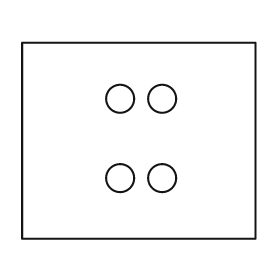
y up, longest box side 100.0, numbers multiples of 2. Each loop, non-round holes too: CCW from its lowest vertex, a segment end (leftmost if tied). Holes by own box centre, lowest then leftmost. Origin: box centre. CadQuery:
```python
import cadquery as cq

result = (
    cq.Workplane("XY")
    .moveTo(-50.0, -42.0)
    .lineTo(50.0, -42.0)
    .lineTo(50.0, 42.0)
    .lineTo(-50.0, 42.0)
    .close()
    .moveTo(-8.0, -16.0)
    .circle(6.0)
    .moveTo(10.0, -16.0)
    .circle(6.0)
    .moveTo(-8.0, 18.0)
    .circle(6.0)
    .moveTo(10.0, 18.0)
    .circle(6.0)
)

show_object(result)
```